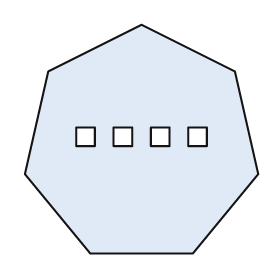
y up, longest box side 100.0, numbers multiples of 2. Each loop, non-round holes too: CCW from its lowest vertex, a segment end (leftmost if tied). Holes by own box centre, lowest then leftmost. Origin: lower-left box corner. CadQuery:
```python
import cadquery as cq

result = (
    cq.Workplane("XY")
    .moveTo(28.0, 0.0)
    .lineTo(72.0, 0.0)
    .lineTo(100.0, 34.0)
    .lineTo(90.0, 78.0)
    .lineTo(50.0, 98.0)
    .lineTo(10.0, 78.0)
    .lineTo(0.0, 34.0)
    .close()
    .moveTo(22.0, 46.0)
    .lineTo(30.0, 46.0)
    .lineTo(30.0, 54.0)
    .lineTo(22.0, 54.0)
    .close()
    .moveTo(38.0, 46.0)
    .lineTo(46.0, 46.0)
    .lineTo(46.0, 54.0)
    .lineTo(38.0, 54.0)
    .close()
    .moveTo(54.0, 46.0)
    .lineTo(62.0, 46.0)
    .lineTo(62.0, 54.0)
    .lineTo(54.0, 54.0)
    .close()
    .moveTo(70.0, 46.0)
    .lineTo(78.0, 46.0)
    .lineTo(78.0, 54.0)
    .lineTo(70.0, 54.0)
    .close()
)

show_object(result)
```